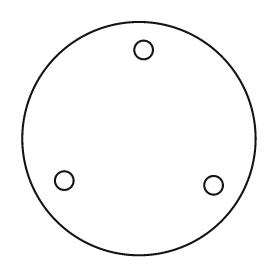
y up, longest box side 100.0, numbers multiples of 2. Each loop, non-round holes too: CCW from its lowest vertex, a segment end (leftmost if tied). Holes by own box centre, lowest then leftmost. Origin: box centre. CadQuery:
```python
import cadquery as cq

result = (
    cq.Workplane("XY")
    .moveTo(0.0, 0.0)
    .circle(50.0)
    .moveTo(32.0, -20.0)
    .circle(4.0)
    .moveTo(-32.0, -18.0)
    .circle(4.0)
    .moveTo(2.0, 38.0)
    .circle(4.0)
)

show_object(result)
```